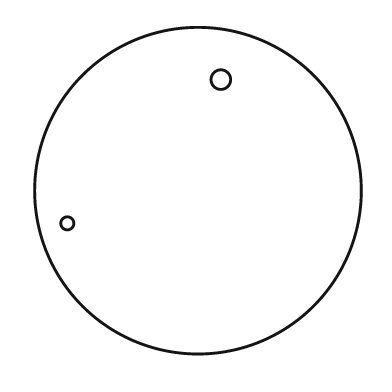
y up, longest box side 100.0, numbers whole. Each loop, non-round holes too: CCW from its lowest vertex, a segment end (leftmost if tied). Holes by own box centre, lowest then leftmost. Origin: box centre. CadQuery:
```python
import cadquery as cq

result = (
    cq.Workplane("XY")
    .moveTo(0.0, 0.0)
    .circle(50.0)
    .moveTo(-40.0, -10.0)
    .circle(2.0)
    .moveTo(7.0, 34.0)
    .circle(3.0)
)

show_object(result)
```